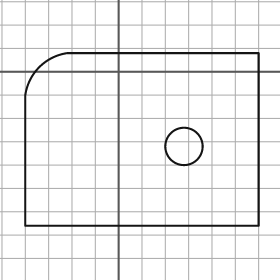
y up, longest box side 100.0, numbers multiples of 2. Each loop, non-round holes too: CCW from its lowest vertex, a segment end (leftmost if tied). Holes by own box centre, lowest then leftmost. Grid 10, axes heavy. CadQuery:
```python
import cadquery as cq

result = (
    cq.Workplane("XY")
    .moveTo(-40.0, -66.0)
    .lineTo(60.0, -66.0)
    .lineTo(60.0, 8.0)
    .lineTo(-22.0, 8.0)
    .threePointArc((-34.0, 2.0), (-40.0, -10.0))
    .close()
    .moveTo(28.0, -32.0)
    .circle(8.0)
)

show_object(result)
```